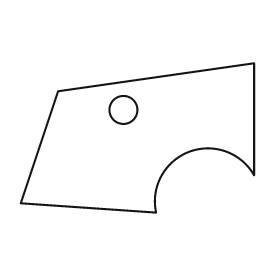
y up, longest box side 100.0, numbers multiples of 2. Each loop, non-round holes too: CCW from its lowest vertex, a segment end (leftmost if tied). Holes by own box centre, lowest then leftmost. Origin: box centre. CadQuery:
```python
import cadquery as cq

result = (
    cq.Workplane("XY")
    .moveTo(8.0, -32.0)
    .threePointArc((22.0, -6.0), (50.0, -16.0))
    .lineTo(50.0, 32.0)
    .lineTo(-34.0, 20.0)
    .lineTo(-50.0, -28.0)
    .close()
    .moveTo(-6.0, 12.0)
    .circle(6.0)
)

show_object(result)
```